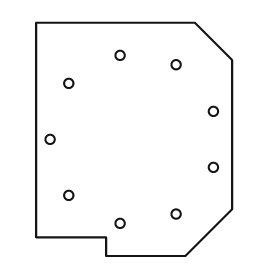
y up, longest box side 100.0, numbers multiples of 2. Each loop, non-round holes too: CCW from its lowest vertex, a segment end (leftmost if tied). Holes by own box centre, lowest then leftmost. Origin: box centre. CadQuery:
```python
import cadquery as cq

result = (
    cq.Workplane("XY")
    .moveTo(-12.0, -50.0)
    .lineTo(22.0, -50.0)
    .lineTo(42.0, -30.0)
    .lineTo(42.0, 34.0)
    .lineTo(26.0, 50.0)
    .lineTo(-42.0, 50.0)
    .lineTo(-42.0, -42.0)
    .lineTo(-12.0, -42.0)
    .close()
    .moveTo(-6.0, -36.0)
    .circle(2.0)
    .moveTo(18.0, -32.0)
    .circle(2.0)
    .moveTo(-28.0, -24.0)
    .circle(2.0)
    .moveTo(34.0, -12.0)
    .circle(2.0)
    .moveTo(-36.0, 0.0)
    .circle(2.0)
    .moveTo(34.0, 12.0)
    .circle(2.0)
    .moveTo(-28.0, 24.0)
    .circle(2.0)
    .moveTo(18.0, 32.0)
    .circle(2.0)
    .moveTo(-6.0, 36.0)
    .circle(2.0)
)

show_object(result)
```